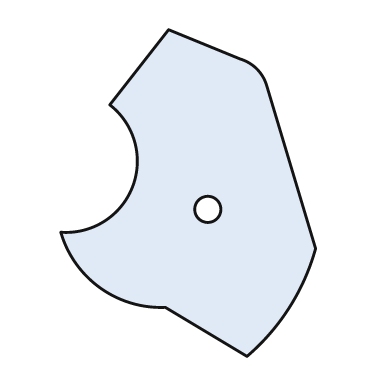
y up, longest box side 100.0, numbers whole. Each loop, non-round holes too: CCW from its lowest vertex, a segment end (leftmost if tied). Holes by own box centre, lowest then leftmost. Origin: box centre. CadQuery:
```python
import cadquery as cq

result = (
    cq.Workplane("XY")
    .moveTo(18.0, -50.0)
    .threePointArc((31.0, -35.0), (39.0, -17.0))
    .lineTo(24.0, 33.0)
    .threePointArc((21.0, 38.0), (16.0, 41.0))
    .lineTo(-6.0, 50.0)
    .lineTo(-24.0, 27.0)
    .threePointArc((-17.0, 2.0), (-39.0, -12.0))
    .threePointArc((-27.0, -29.0), (-7.0, -35.0))
    .close()
    .moveTo(6.0, -5.0)
    .circle(4.0)
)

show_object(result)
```